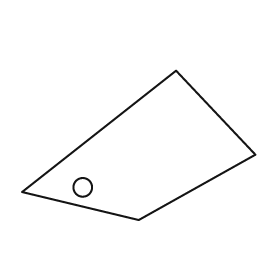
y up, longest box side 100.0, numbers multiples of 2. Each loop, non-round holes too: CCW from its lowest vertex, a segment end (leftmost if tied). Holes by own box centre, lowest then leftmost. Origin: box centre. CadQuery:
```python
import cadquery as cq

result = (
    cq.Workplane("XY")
    .moveTo(0.0, -32.0)
    .lineTo(50.0, -4.0)
    .lineTo(16.0, 32.0)
    .lineTo(-50.0, -20.0)
    .close()
    .moveTo(-24.0, -18.0)
    .circle(4.0)
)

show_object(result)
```